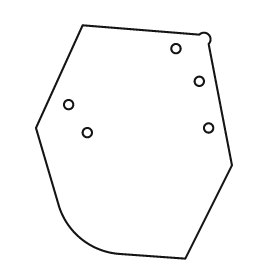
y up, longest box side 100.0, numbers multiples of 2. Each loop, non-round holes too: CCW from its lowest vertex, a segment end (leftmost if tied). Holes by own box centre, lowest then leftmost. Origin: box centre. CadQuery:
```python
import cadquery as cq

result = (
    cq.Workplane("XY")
    .moveTo(22.0, -50.0)
    .lineTo(42.0, -10.0)
    .lineTo(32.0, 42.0)
    .threePointArc((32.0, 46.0), (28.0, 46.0))
    .lineTo(-22.0, 50.0)
    .lineTo(-42.0, 6.0)
    .lineTo(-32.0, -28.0)
    .threePointArc((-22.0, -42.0), (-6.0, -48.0))
    .close()
    .moveTo(-20.0, 4.0)
    .circle(2.0)
    .moveTo(32.0, 6.0)
    .circle(2.0)
    .moveTo(-28.0, 16.0)
    .circle(2.0)
    .moveTo(28.0, 26.0)
    .circle(2.0)
    .moveTo(18.0, 40.0)
    .circle(2.0)
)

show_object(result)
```